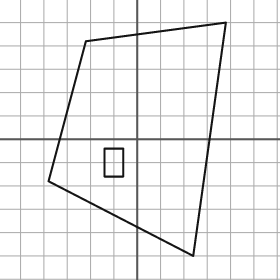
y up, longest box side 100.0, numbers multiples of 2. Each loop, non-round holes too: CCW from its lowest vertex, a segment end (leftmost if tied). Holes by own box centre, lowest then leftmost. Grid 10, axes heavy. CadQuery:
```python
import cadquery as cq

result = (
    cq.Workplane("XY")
    .moveTo(24.0, -50.0)
    .lineTo(38.0, 50.0)
    .lineTo(-22.0, 42.0)
    .lineTo(-38.0, -18.0)
    .close()
    .moveTo(-14.0, -16.0)
    .lineTo(-6.0, -16.0)
    .lineTo(-6.0, -4.0)
    .lineTo(-14.0, -4.0)
    .close()
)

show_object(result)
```